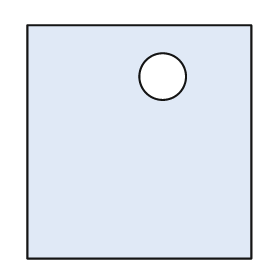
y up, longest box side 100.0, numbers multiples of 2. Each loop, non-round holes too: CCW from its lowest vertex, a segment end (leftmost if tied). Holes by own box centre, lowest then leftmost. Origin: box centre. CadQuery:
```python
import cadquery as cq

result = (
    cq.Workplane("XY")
    .moveTo(-48.0, -50.0)
    .lineTo(48.0, -50.0)
    .lineTo(48.0, 50.0)
    .lineTo(-48.0, 50.0)
    .close()
    .moveTo(10.0, 28.0)
    .circle(10.0)
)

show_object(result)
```